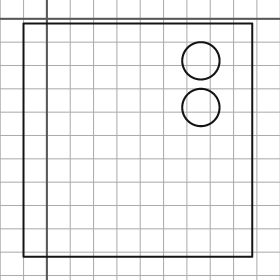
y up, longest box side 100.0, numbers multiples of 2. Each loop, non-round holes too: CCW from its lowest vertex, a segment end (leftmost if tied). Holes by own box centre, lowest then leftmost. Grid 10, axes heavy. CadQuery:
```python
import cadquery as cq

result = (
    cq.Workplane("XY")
    .moveTo(-10.0, -102.0)
    .lineTo(88.0, -102.0)
    .lineTo(88.0, -2.0)
    .lineTo(-10.0, -2.0)
    .close()
    .moveTo(66.0, -38.0)
    .circle(8.0)
    .moveTo(66.0, -18.0)
    .circle(8.0)
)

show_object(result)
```